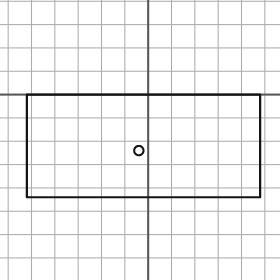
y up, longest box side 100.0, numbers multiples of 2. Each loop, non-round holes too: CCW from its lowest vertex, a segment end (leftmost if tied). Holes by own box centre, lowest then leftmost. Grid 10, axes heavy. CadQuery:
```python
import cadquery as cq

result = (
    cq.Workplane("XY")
    .moveTo(-52.0, -44.0)
    .lineTo(48.0, -44.0)
    .lineTo(48.0, 0.0)
    .lineTo(-52.0, 0.0)
    .close()
    .moveTo(-4.0, -24.0)
    .circle(2.0)
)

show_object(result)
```